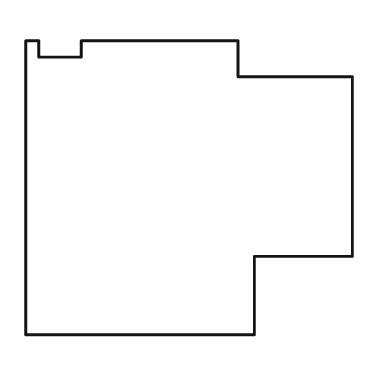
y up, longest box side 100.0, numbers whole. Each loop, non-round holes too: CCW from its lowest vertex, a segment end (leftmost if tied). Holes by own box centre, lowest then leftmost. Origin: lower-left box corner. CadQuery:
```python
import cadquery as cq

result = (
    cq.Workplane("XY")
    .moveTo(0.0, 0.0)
    .lineTo(70.0, 0.0)
    .lineTo(70.0, 24.0)
    .lineTo(100.0, 24.0)
    .lineTo(100.0, 79.0)
    .lineTo(65.0, 79.0)
    .lineTo(65.0, 90.0)
    .lineTo(17.0, 90.0)
    .lineTo(17.0, 85.0)
    .lineTo(4.0, 85.0)
    .lineTo(4.0, 90.0)
    .lineTo(0.0, 90.0)
    .close()
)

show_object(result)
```